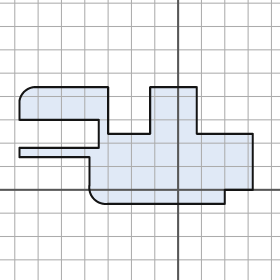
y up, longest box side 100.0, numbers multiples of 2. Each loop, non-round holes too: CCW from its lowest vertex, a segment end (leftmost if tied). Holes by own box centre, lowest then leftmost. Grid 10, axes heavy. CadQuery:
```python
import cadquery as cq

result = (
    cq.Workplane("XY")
    .moveTo(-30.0, -6.0)
    .lineTo(20.0, -6.0)
    .lineTo(20.0, 0.0)
    .lineTo(32.0, 0.0)
    .lineTo(32.0, 24.0)
    .lineTo(8.0, 24.0)
    .lineTo(8.0, 44.0)
    .lineTo(-12.0, 44.0)
    .lineTo(-12.0, 24.0)
    .lineTo(-30.0, 24.0)
    .lineTo(-30.0, 44.0)
    .lineTo(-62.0, 44.0)
    .threePointArc((-66.0, 42.0), (-68.0, 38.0))
    .lineTo(-68.0, 30.0)
    .lineTo(-34.0, 30.0)
    .lineTo(-34.0, 18.0)
    .lineTo(-68.0, 18.0)
    .lineTo(-68.0, 14.0)
    .lineTo(-38.0, 14.0)
    .lineTo(-38.0, 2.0)
    .threePointArc((-36.0, -4.0), (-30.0, -6.0))
    .close()
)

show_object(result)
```